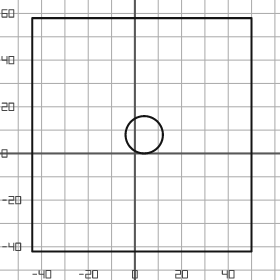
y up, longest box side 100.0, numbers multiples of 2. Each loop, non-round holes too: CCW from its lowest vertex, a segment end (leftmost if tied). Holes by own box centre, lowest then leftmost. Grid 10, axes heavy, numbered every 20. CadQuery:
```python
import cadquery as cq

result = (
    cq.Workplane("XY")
    .moveTo(-44.0, -42.0)
    .lineTo(50.0, -42.0)
    .lineTo(50.0, 58.0)
    .lineTo(-44.0, 58.0)
    .close()
    .moveTo(4.0, 8.0)
    .circle(8.0)
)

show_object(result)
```